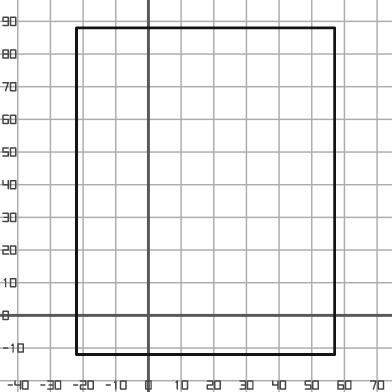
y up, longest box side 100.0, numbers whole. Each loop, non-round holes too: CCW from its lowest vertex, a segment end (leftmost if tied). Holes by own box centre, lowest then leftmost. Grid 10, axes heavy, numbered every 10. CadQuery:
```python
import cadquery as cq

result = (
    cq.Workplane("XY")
    .moveTo(-22.0, -12.0)
    .lineTo(57.0, -12.0)
    .lineTo(57.0, 88.0)
    .lineTo(-22.0, 88.0)
    .close()
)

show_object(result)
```